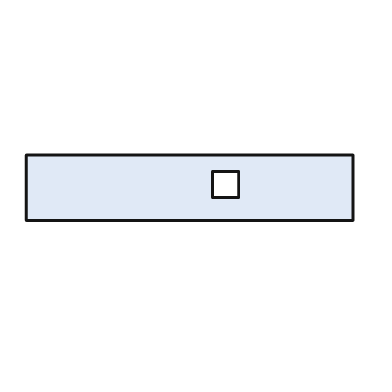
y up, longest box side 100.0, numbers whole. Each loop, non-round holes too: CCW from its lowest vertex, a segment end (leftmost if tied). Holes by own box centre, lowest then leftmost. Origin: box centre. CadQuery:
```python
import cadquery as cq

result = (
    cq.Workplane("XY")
    .moveTo(-50.0, -10.0)
    .lineTo(50.0, -10.0)
    .lineTo(50.0, 10.0)
    .lineTo(-50.0, 10.0)
    .close()
    .moveTo(7.0, -3.0)
    .lineTo(15.0, -3.0)
    .lineTo(15.0, 5.0)
    .lineTo(7.0, 5.0)
    .close()
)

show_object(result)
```